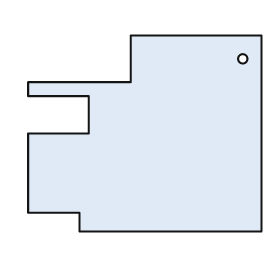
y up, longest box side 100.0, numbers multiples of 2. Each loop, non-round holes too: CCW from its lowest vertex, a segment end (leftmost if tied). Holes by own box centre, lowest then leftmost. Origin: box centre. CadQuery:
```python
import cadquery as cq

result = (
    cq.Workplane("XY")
    .moveTo(-28.0, -42.0)
    .lineTo(50.0, -42.0)
    .lineTo(50.0, 42.0)
    .lineTo(-6.0, 42.0)
    .lineTo(-6.0, 22.0)
    .lineTo(-50.0, 22.0)
    .lineTo(-50.0, 16.0)
    .lineTo(-24.0, 16.0)
    .lineTo(-24.0, 0.0)
    .lineTo(-50.0, 0.0)
    .lineTo(-50.0, -34.0)
    .lineTo(-28.0, -34.0)
    .close()
    .moveTo(42.0, 32.0)
    .circle(2.0)
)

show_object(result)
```